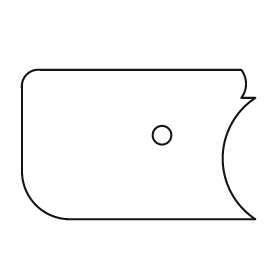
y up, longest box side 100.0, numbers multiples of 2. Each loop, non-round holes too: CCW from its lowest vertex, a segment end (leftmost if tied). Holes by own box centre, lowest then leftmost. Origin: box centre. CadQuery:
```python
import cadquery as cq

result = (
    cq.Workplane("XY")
    .moveTo(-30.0, -32.0)
    .lineTo(50.0, -32.0)
    .threePointArc((36.0, -6.0), (50.0, 20.0))
    .lineTo(44.0, 20.0)
    .threePointArc((46.0, 26.0), (44.0, 32.0))
    .lineTo(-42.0, 32.0)
    .threePointArc((-48.0, 30.0), (-50.0, 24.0))
    .lineTo(-50.0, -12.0)
    .threePointArc((-44.0, -26.0), (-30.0, -32.0))
    .close()
    .moveTo(10.0, 4.0)
    .circle(4.0)
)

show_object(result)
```